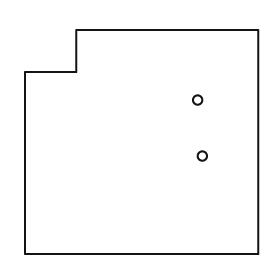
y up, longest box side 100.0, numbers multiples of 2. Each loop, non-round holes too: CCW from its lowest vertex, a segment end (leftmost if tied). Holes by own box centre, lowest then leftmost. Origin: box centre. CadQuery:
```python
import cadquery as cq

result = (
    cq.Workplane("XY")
    .moveTo(-50.0, -48.0)
    .lineTo(50.0, -48.0)
    .lineTo(50.0, 48.0)
    .lineTo(-28.0, 48.0)
    .lineTo(-28.0, 30.0)
    .lineTo(-50.0, 30.0)
    .close()
    .moveTo(26.0, -6.0)
    .circle(2.0)
    .moveTo(24.0, 18.0)
    .circle(2.0)
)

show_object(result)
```